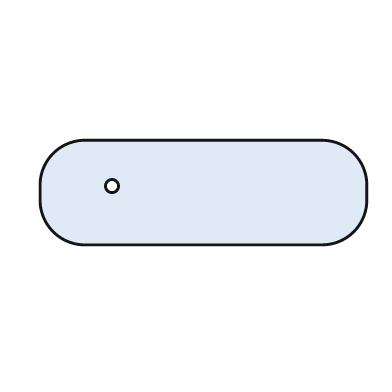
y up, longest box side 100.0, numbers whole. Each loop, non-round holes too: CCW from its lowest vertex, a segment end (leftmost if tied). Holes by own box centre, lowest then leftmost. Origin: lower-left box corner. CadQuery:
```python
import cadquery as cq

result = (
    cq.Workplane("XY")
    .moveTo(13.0, 0.0)
    .lineTo(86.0, 0.0)
    .threePointArc((96.0, 4.0), (100.0, 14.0))
    .lineTo(100.0, 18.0)
    .threePointArc((96.0, 28.0), (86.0, 32.0))
    .lineTo(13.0, 32.0)
    .threePointArc((4.0, 28.0), (0.0, 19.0))
    .lineTo(0.0, 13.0)
    .threePointArc((4.0, 4.0), (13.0, 0.0))
    .close()
    .moveTo(22.0, 18.0)
    .circle(2.0)
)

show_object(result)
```